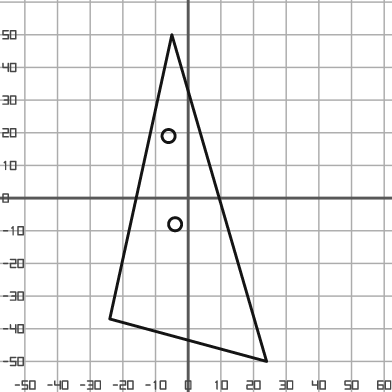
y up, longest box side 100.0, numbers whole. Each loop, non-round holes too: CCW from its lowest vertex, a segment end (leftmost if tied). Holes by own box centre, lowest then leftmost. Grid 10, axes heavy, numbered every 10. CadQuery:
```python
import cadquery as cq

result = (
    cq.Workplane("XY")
    .moveTo(24.0, -50.0)
    .lineTo(-5.0, 50.0)
    .lineTo(-24.0, -37.0)
    .close()
    .moveTo(-4.0, -8.0)
    .circle(2.0)
    .moveTo(-6.0, 19.0)
    .circle(2.0)
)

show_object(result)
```